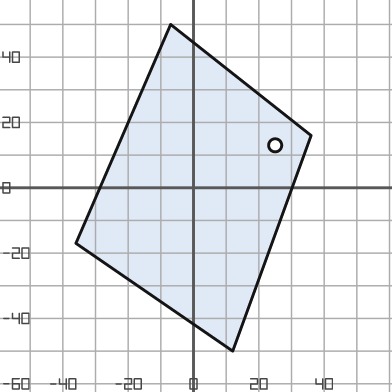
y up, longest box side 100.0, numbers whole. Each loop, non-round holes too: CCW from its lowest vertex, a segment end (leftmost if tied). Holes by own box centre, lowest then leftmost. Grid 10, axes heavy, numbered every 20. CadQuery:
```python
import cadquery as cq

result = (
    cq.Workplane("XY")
    .moveTo(12.0, -50.0)
    .lineTo(36.0, 16.0)
    .lineTo(-7.0, 50.0)
    .lineTo(-36.0, -17.0)
    .close()
    .moveTo(25.0, 13.0)
    .circle(2.0)
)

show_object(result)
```